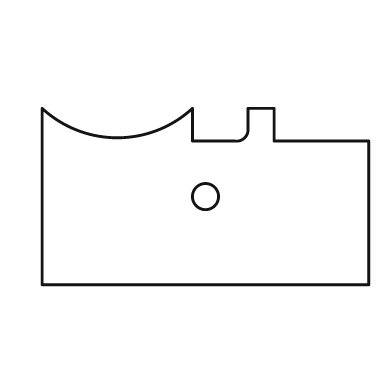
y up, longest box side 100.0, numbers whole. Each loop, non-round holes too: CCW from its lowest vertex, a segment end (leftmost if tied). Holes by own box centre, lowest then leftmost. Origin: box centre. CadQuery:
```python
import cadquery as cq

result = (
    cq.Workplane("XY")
    .moveTo(-50.0, -27.0)
    .lineTo(50.0, -27.0)
    .lineTo(50.0, 17.0)
    .lineTo(21.0, 17.0)
    .lineTo(21.0, 27.0)
    .lineTo(13.0, 27.0)
    .lineTo(13.0, 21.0)
    .threePointArc((12.0, 18.0), (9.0, 17.0))
    .lineTo(-4.0, 17.0)
    .lineTo(-4.0, 27.0)
    .threePointArc((-27.0, 18.0), (-50.0, 27.0))
    .close()
    .moveTo(0.0, 0.0)
    .circle(4.0)
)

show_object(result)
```